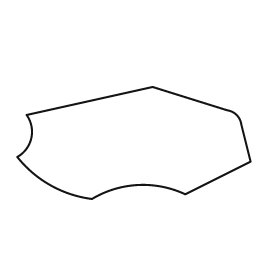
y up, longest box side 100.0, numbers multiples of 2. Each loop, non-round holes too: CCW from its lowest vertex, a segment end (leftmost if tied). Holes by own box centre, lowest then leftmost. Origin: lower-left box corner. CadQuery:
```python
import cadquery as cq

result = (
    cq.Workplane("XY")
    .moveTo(32.0, 0.0)
    .threePointArc((52.0, 6.0), (72.0, 2.0))
    .lineTo(100.0, 16.0)
    .lineTo(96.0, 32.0)
    .threePointArc((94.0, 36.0), (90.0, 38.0))
    .lineTo(58.0, 48.0)
    .lineTo(4.0, 36.0)
    .threePointArc((6.0, 26.0), (0.0, 18.0))
    .threePointArc((14.0, 6.0), (32.0, 0.0))
    .close()
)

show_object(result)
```